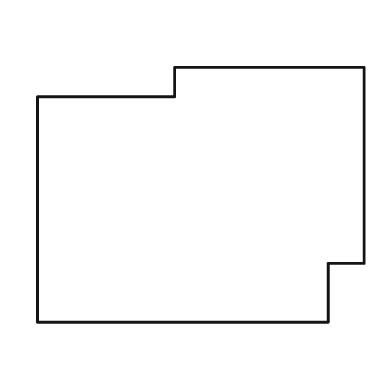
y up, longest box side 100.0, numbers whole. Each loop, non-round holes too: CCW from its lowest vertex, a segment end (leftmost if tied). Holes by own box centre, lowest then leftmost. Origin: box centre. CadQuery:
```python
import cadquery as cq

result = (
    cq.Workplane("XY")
    .moveTo(-50.0, -39.0)
    .lineTo(39.0, -39.0)
    .lineTo(39.0, -21.0)
    .lineTo(50.0, -21.0)
    .lineTo(50.0, 39.0)
    .lineTo(-8.0, 39.0)
    .lineTo(-8.0, 30.0)
    .lineTo(-50.0, 30.0)
    .close()
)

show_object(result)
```